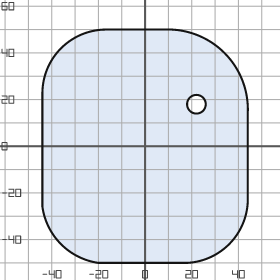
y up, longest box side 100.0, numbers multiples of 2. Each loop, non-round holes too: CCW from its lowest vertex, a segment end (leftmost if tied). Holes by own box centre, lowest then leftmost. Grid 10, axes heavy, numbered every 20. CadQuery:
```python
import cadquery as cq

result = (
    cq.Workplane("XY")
    .moveTo(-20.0, -50.0)
    .lineTo(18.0, -50.0)
    .threePointArc((36.0, -42.0), (44.0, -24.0))
    .lineTo(44.0, 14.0)
    .threePointArc((34.0, 40.0), (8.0, 50.0))
    .lineTo(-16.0, 50.0)
    .threePointArc((-36.0, 42.0), (-44.0, 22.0))
    .lineTo(-44.0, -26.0)
    .threePointArc((-36.0, -42.0), (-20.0, -50.0))
    .close()
    .moveTo(22.0, 18.0)
    .circle(4.0)
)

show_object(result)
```